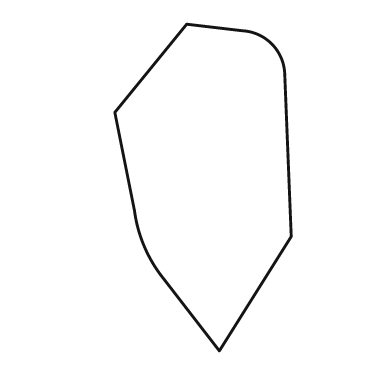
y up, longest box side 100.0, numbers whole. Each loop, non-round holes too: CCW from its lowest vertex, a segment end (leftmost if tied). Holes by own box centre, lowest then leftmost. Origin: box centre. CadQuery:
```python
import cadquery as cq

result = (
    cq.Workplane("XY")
    .moveTo(5.0, -50.0)
    .lineTo(27.0, -15.0)
    .lineTo(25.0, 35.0)
    .threePointArc((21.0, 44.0), (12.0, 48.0))
    .lineTo(-5.0, 50.0)
    .lineTo(-27.0, 23.0)
    .lineTo(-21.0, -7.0)
    .threePointArc((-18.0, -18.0), (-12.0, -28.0))
    .close()
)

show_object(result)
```